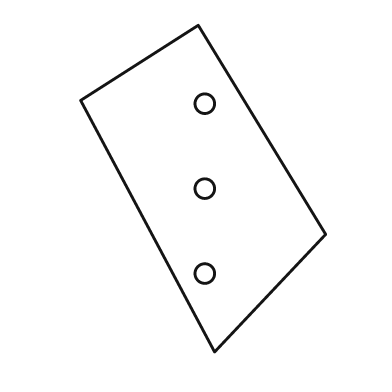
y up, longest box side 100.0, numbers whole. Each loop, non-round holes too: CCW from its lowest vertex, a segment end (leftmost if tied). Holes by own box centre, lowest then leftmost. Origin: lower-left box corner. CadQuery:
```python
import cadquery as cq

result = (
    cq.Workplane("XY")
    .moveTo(41.0, 0.0)
    .lineTo(75.0, 36.0)
    .lineTo(36.0, 100.0)
    .lineTo(0.0, 77.0)
    .close()
    .moveTo(38.0, 24.0)
    .circle(3.0)
    .moveTo(38.0, 50.0)
    .circle(3.0)
    .moveTo(38.0, 76.0)
    .circle(3.0)
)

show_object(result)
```